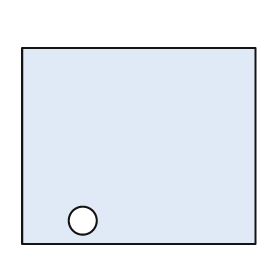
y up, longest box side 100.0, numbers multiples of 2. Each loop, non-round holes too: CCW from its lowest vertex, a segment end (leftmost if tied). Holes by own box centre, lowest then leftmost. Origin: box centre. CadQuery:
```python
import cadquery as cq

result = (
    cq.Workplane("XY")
    .moveTo(-50.0, -42.0)
    .lineTo(50.0, -42.0)
    .lineTo(50.0, 42.0)
    .lineTo(-50.0, 42.0)
    .close()
    .moveTo(-24.0, -32.0)
    .circle(6.0)
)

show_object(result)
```